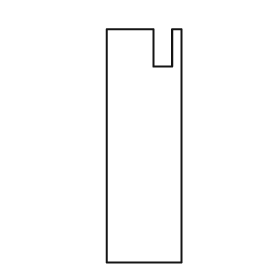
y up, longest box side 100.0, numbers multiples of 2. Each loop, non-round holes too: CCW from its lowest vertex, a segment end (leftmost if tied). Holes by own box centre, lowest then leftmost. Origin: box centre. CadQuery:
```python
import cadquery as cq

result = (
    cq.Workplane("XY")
    .moveTo(-16.0, -50.0)
    .lineTo(16.0, -50.0)
    .lineTo(16.0, 50.0)
    .lineTo(12.0, 50.0)
    .lineTo(12.0, 34.0)
    .lineTo(4.0, 34.0)
    .lineTo(4.0, 50.0)
    .lineTo(-16.0, 50.0)
    .close()
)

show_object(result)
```